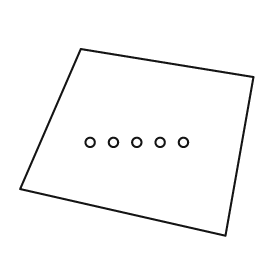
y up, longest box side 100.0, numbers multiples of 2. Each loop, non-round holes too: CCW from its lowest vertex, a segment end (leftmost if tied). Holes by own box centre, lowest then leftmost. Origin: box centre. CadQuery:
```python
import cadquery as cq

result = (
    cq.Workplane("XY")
    .moveTo(38.0, -40.0)
    .lineTo(50.0, 28.0)
    .lineTo(-24.0, 40.0)
    .lineTo(-50.0, -20.0)
    .close()
    .moveTo(-20.0, 0.0)
    .circle(2.0)
    .moveTo(-10.0, 0.0)
    .circle(2.0)
    .moveTo(0.0, 0.0)
    .circle(2.0)
    .moveTo(10.0, 0.0)
    .circle(2.0)
    .moveTo(20.0, 0.0)
    .circle(2.0)
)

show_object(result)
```